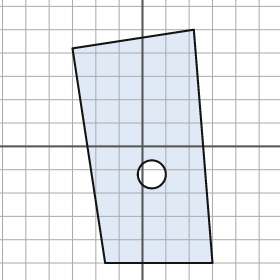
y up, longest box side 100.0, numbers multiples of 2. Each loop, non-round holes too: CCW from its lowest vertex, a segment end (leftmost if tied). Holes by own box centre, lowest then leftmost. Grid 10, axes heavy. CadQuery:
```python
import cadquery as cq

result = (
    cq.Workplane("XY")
    .moveTo(-16.0, -50.0)
    .lineTo(30.0, -50.0)
    .lineTo(22.0, 50.0)
    .lineTo(-30.0, 42.0)
    .close()
    .moveTo(4.0, -12.0)
    .circle(6.0)
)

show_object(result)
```